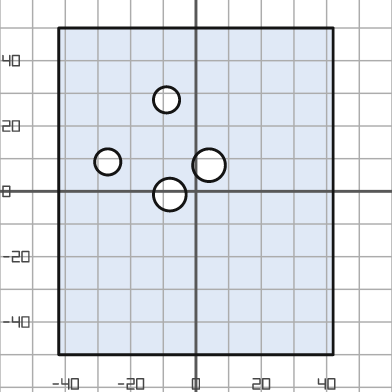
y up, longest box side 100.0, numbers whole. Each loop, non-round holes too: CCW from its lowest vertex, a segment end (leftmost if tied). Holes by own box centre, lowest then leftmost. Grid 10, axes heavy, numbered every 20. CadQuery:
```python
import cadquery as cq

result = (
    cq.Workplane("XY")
    .moveTo(-42.0, -50.0)
    .lineTo(42.0, -50.0)
    .lineTo(42.0, 50.0)
    .lineTo(-42.0, 50.0)
    .close()
    .moveTo(-8.0, -1.0)
    .circle(5.0)
    .moveTo(4.0, 8.0)
    .circle(5.0)
    .moveTo(-27.0, 9.0)
    .circle(4.0)
    .moveTo(-9.0, 28.0)
    .circle(4.0)
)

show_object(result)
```